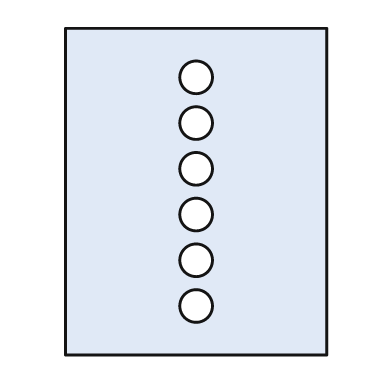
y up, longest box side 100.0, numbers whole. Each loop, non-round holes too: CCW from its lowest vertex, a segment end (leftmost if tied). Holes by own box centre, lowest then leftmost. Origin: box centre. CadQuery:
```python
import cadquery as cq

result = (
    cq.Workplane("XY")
    .moveTo(-40.0, -50.0)
    .lineTo(40.0, -50.0)
    .lineTo(40.0, 50.0)
    .lineTo(-40.0, 50.0)
    .close()
    .moveTo(0.0, -35.0)
    .circle(5.0)
    .moveTo(0.0, -21.0)
    .circle(5.0)
    .moveTo(0.0, -7.0)
    .circle(5.0)
    .moveTo(0.0, 7.0)
    .circle(5.0)
    .moveTo(0.0, 21.0)
    .circle(5.0)
    .moveTo(0.0, 35.0)
    .circle(5.0)
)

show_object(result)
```